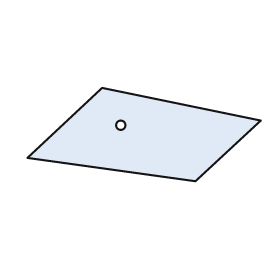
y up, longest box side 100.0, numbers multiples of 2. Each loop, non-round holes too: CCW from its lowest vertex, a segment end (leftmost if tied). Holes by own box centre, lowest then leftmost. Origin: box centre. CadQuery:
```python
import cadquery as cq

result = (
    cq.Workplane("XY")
    .moveTo(22.0, -20.0)
    .lineTo(50.0, 6.0)
    .lineTo(-18.0, 20.0)
    .lineTo(-50.0, -10.0)
    .close()
    .moveTo(-10.0, 4.0)
    .circle(2.0)
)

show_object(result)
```